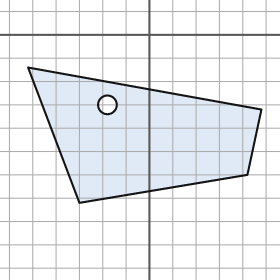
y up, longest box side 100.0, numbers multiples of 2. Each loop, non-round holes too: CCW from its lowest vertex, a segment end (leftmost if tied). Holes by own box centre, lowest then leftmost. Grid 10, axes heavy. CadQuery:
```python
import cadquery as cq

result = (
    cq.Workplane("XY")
    .moveTo(-30.0, -72.0)
    .lineTo(42.0, -60.0)
    .lineTo(48.0, -32.0)
    .lineTo(-52.0, -14.0)
    .close()
    .moveTo(-18.0, -30.0)
    .circle(4.0)
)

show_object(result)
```